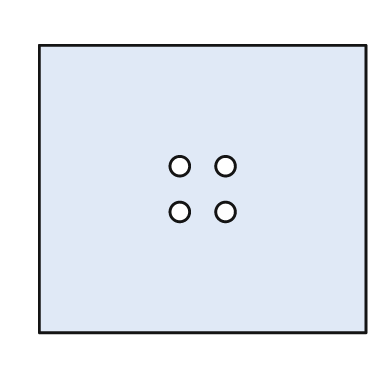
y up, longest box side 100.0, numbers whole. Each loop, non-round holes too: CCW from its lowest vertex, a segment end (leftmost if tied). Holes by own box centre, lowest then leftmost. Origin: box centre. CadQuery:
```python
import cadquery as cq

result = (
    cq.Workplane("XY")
    .moveTo(-50.0, -44.0)
    .lineTo(50.0, -44.0)
    .lineTo(50.0, 44.0)
    .lineTo(-50.0, 44.0)
    .close()
    .moveTo(-7.0, -7.0)
    .circle(3.0)
    .moveTo(7.0, -7.0)
    .circle(3.0)
    .moveTo(-7.0, 7.0)
    .circle(3.0)
    .moveTo(7.0, 7.0)
    .circle(3.0)
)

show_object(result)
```